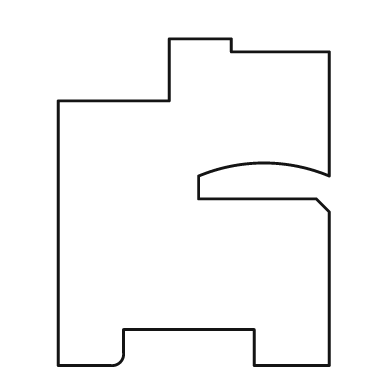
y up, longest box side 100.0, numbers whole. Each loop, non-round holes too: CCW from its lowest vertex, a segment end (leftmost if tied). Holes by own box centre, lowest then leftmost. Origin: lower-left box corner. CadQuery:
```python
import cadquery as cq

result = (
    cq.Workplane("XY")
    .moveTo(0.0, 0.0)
    .lineTo(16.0, 0.0)
    .threePointArc((19.0, 1.0), (20.0, 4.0))
    .lineTo(20.0, 11.0)
    .lineTo(60.0, 11.0)
    .lineTo(60.0, 0.0)
    .lineTo(83.0, 0.0)
    .lineTo(83.0, 47.0)
    .lineTo(79.0, 51.0)
    .lineTo(43.0, 51.0)
    .lineTo(43.0, 58.0)
    .threePointArc((63.0, 62.0), (83.0, 58.0))
    .lineTo(83.0, 96.0)
    .lineTo(53.0, 96.0)
    .lineTo(53.0, 100.0)
    .lineTo(34.0, 100.0)
    .lineTo(34.0, 81.0)
    .lineTo(0.0, 81.0)
    .close()
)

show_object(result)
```